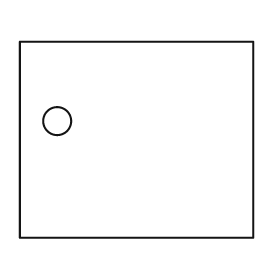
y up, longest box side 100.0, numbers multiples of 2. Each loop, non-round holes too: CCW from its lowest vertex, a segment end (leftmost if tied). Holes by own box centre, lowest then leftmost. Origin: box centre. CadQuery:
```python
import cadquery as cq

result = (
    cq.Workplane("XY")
    .moveTo(-50.0, -42.0)
    .lineTo(50.0, -42.0)
    .lineTo(50.0, 42.0)
    .lineTo(-50.0, 42.0)
    .close()
    .moveTo(-34.0, 8.0)
    .circle(6.0)
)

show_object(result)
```